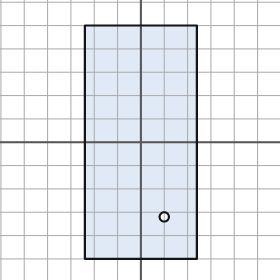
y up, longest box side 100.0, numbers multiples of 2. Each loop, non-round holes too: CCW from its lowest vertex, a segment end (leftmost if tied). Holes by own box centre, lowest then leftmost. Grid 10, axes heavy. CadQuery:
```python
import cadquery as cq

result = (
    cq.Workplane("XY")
    .moveTo(-24.0, -50.0)
    .lineTo(24.0, -50.0)
    .lineTo(24.0, 50.0)
    .lineTo(-24.0, 50.0)
    .close()
    .moveTo(10.0, -32.0)
    .circle(2.0)
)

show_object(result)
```